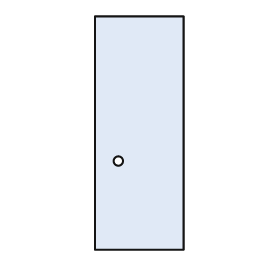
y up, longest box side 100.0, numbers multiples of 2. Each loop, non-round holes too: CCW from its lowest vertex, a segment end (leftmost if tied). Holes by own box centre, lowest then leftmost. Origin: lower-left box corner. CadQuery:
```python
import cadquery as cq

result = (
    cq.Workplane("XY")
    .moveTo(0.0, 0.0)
    .lineTo(38.0, 0.0)
    .lineTo(38.0, 100.0)
    .lineTo(0.0, 100.0)
    .close()
    .moveTo(10.0, 38.0)
    .circle(2.0)
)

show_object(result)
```